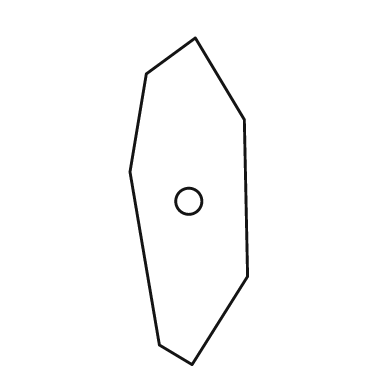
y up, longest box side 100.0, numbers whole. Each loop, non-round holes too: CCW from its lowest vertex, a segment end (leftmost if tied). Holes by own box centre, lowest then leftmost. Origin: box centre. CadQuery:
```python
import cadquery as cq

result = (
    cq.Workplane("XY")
    .moveTo(1.0, -50.0)
    .lineTo(18.0, -23.0)
    .lineTo(17.0, 25.0)
    .lineTo(2.0, 50.0)
    .lineTo(-13.0, 39.0)
    .lineTo(-18.0, 9.0)
    .lineTo(-9.0, -44.0)
    .close()
    .moveTo(0.0, 0.0)
    .circle(4.0)
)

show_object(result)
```